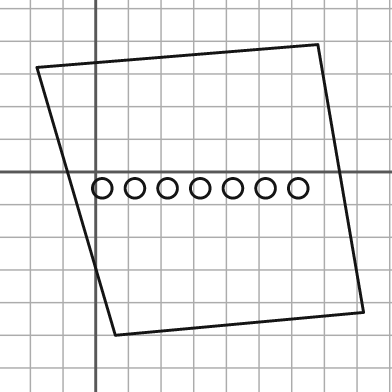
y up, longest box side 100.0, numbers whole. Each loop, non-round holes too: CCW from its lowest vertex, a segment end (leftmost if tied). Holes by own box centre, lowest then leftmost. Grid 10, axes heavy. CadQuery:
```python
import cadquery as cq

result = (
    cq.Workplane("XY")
    .moveTo(6.0, -50.0)
    .lineTo(82.0, -43.0)
    .lineTo(68.0, 39.0)
    .lineTo(-18.0, 32.0)
    .close()
    .moveTo(2.0, -5.0)
    .circle(3.0)
    .moveTo(12.0, -5.0)
    .circle(3.0)
    .moveTo(22.0, -5.0)
    .circle(3.0)
    .moveTo(32.0, -5.0)
    .circle(3.0)
    .moveTo(42.0, -5.0)
    .circle(3.0)
    .moveTo(52.0, -5.0)
    .circle(3.0)
    .moveTo(62.0, -5.0)
    .circle(3.0)
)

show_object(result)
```